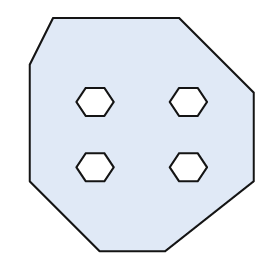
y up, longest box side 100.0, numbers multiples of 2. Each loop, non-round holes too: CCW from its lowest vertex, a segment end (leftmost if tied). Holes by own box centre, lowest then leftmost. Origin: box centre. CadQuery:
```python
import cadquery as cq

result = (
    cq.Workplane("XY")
    .moveTo(-18.0, -50.0)
    .lineTo(10.0, -50.0)
    .lineTo(48.0, -20.0)
    .lineTo(48.0, 18.0)
    .lineTo(16.0, 50.0)
    .lineTo(-38.0, 50.0)
    .lineTo(-48.0, 30.0)
    .lineTo(-48.0, -20.0)
    .close()
    .moveTo(-24.0, -20.0)
    .lineTo(-16.0, -20.0)
    .lineTo(-12.0, -14.0)
    .lineTo(-16.0, -8.0)
    .lineTo(-24.0, -8.0)
    .lineTo(-28.0, -14.0)
    .close()
    .moveTo(16.0, -20.0)
    .lineTo(24.0, -20.0)
    .lineTo(28.0, -14.0)
    .lineTo(24.0, -8.0)
    .lineTo(16.0, -8.0)
    .lineTo(12.0, -14.0)
    .close()
    .moveTo(-24.0, 8.0)
    .lineTo(-16.0, 8.0)
    .lineTo(-12.0, 14.0)
    .lineTo(-16.0, 20.0)
    .lineTo(-24.0, 20.0)
    .lineTo(-28.0, 14.0)
    .close()
    .moveTo(16.0, 8.0)
    .lineTo(24.0, 8.0)
    .lineTo(28.0, 14.0)
    .lineTo(24.0, 20.0)
    .lineTo(16.0, 20.0)
    .lineTo(12.0, 14.0)
    .close()
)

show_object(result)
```